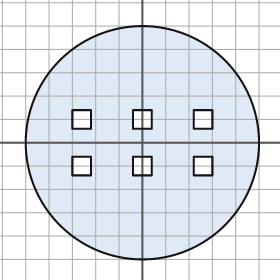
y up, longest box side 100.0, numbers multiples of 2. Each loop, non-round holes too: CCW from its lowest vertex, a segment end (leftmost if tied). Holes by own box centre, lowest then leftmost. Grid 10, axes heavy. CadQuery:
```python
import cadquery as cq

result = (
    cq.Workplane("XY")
    .moveTo(0.0, 0.0)
    .circle(50.0)
    .moveTo(-30.0, -14.0)
    .lineTo(-22.0, -14.0)
    .lineTo(-22.0, -6.0)
    .lineTo(-30.0, -6.0)
    .close()
    .moveTo(-4.0, -14.0)
    .lineTo(4.0, -14.0)
    .lineTo(4.0, -6.0)
    .lineTo(-4.0, -6.0)
    .close()
    .moveTo(22.0, -14.0)
    .lineTo(30.0, -14.0)
    .lineTo(30.0, -6.0)
    .lineTo(22.0, -6.0)
    .close()
    .moveTo(-30.0, 6.0)
    .lineTo(-22.0, 6.0)
    .lineTo(-22.0, 14.0)
    .lineTo(-30.0, 14.0)
    .close()
    .moveTo(-4.0, 6.0)
    .lineTo(4.0, 6.0)
    .lineTo(4.0, 14.0)
    .lineTo(-4.0, 14.0)
    .close()
    .moveTo(22.0, 6.0)
    .lineTo(30.0, 6.0)
    .lineTo(30.0, 14.0)
    .lineTo(22.0, 14.0)
    .close()
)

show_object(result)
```